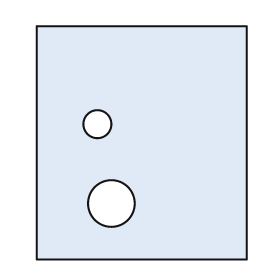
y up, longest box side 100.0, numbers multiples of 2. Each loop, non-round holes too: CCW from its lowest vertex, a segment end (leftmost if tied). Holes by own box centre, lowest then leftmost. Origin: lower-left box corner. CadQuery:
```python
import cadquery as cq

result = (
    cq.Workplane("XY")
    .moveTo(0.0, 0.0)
    .lineTo(90.0, 0.0)
    .lineTo(90.0, 100.0)
    .lineTo(0.0, 100.0)
    .close()
    .moveTo(32.0, 24.0)
    .circle(10.0)
    .moveTo(26.0, 58.0)
    .circle(6.0)
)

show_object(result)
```